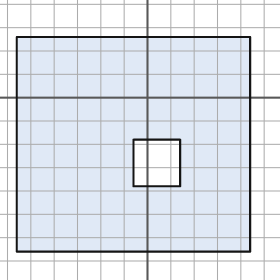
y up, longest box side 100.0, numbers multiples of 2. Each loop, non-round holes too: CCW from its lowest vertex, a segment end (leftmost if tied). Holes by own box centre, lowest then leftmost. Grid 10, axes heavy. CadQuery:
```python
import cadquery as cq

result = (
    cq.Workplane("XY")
    .moveTo(-56.0, -66.0)
    .lineTo(44.0, -66.0)
    .lineTo(44.0, 26.0)
    .lineTo(-56.0, 26.0)
    .close()
    .moveTo(-6.0, -38.0)
    .lineTo(14.0, -38.0)
    .lineTo(14.0, -18.0)
    .lineTo(-6.0, -18.0)
    .close()
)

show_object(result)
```